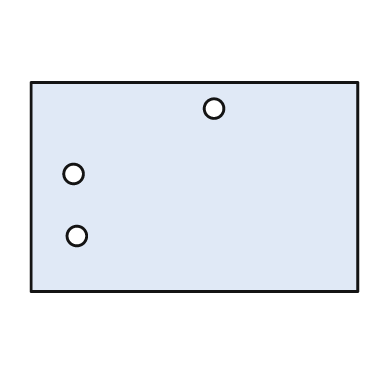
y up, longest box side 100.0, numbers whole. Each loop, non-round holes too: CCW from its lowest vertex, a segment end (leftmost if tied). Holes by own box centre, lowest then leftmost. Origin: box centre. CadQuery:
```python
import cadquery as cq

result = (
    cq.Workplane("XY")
    .moveTo(-50.0, -32.0)
    .lineTo(50.0, -32.0)
    .lineTo(50.0, 32.0)
    .lineTo(-50.0, 32.0)
    .close()
    .moveTo(-36.0, -15.0)
    .circle(3.0)
    .moveTo(-37.0, 4.0)
    .circle(3.0)
    .moveTo(6.0, 24.0)
    .circle(3.0)
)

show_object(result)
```